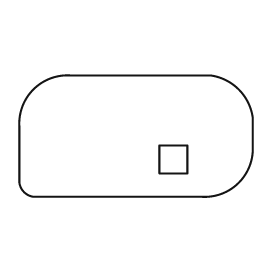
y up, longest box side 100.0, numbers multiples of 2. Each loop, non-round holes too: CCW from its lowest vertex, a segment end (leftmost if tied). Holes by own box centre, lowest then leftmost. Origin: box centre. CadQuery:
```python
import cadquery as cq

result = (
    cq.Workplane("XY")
    .moveTo(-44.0, -26.0)
    .lineTo(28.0, -26.0)
    .threePointArc((44.0, -20.0), (50.0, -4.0))
    .lineTo(50.0, 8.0)
    .threePointArc((44.0, 20.0), (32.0, 26.0))
    .lineTo(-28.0, 26.0)
    .threePointArc((-44.0, 20.0), (-50.0, 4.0))
    .lineTo(-50.0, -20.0)
    .threePointArc((-48.0, -24.0), (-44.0, -26.0))
    .close()
    .moveTo(10.0, -16.0)
    .lineTo(22.0, -16.0)
    .lineTo(22.0, -4.0)
    .lineTo(10.0, -4.0)
    .close()
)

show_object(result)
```